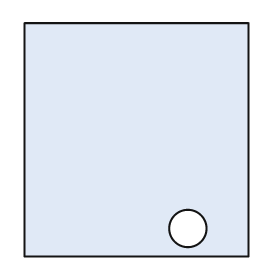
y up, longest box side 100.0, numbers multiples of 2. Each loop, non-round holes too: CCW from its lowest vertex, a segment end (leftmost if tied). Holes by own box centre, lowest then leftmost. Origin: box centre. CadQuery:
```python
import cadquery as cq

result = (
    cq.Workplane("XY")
    .moveTo(-48.0, -50.0)
    .lineTo(48.0, -50.0)
    .lineTo(48.0, 50.0)
    .lineTo(-48.0, 50.0)
    .close()
    .moveTo(22.0, -38.0)
    .circle(8.0)
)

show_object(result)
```